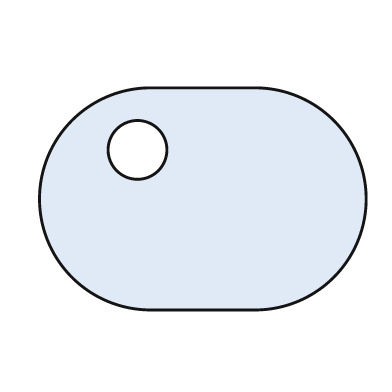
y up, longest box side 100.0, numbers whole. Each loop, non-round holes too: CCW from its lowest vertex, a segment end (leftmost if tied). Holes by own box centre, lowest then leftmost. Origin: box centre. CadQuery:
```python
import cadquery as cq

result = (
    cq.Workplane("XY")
    .moveTo(-16.0, -34.0)
    .lineTo(16.0, -34.0)
    .threePointArc((50.0, 0.0), (16.0, 34.0))
    .lineTo(-16.0, 34.0)
    .threePointArc((-50.0, 0.0), (-16.0, -34.0))
    .close()
    .moveTo(-20.0, 15.0)
    .circle(9.0)
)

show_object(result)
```